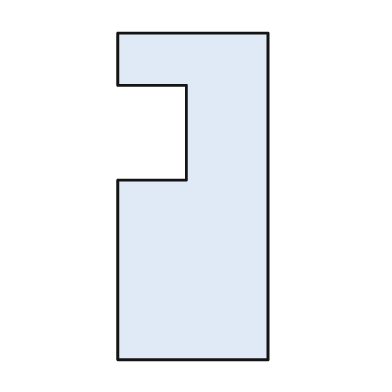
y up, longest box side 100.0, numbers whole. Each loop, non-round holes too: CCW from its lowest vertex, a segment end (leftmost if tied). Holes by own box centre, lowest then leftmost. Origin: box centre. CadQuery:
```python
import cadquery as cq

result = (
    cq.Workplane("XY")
    .moveTo(-23.0, -50.0)
    .lineTo(23.0, -50.0)
    .lineTo(23.0, 50.0)
    .lineTo(-23.0, 50.0)
    .lineTo(-23.0, 34.0)
    .lineTo(-2.0, 34.0)
    .lineTo(-2.0, 5.0)
    .lineTo(-23.0, 5.0)
    .close()
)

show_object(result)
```